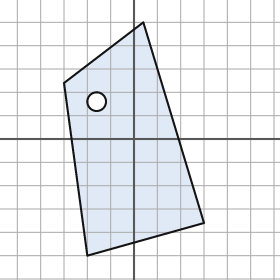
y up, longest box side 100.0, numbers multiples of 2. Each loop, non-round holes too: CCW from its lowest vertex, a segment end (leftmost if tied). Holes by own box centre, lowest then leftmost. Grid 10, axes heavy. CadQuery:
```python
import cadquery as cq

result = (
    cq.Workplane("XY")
    .moveTo(-20.0, -50.0)
    .lineTo(30.0, -36.0)
    .lineTo(4.0, 50.0)
    .lineTo(-30.0, 24.0)
    .close()
    .moveTo(-16.0, 16.0)
    .circle(4.0)
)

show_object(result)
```